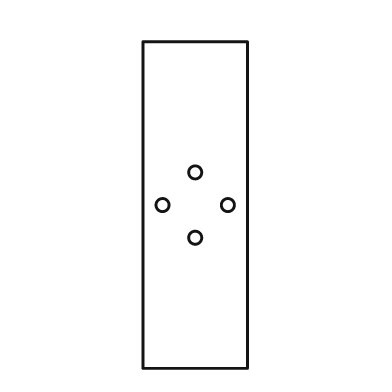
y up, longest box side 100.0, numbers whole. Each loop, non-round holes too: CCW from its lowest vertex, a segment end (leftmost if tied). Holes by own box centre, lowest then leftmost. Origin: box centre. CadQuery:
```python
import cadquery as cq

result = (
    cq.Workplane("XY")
    .moveTo(-16.0, -50.0)
    .lineTo(16.0, -50.0)
    .lineTo(16.0, 50.0)
    .lineTo(-16.0, 50.0)
    .close()
    .moveTo(0.0, -10.0)
    .circle(2.0)
    .moveTo(-10.0, 0.0)
    .circle(2.0)
    .moveTo(10.0, 0.0)
    .circle(2.0)
    .moveTo(0.0, 10.0)
    .circle(2.0)
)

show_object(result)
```